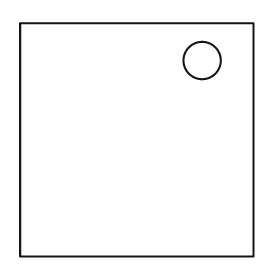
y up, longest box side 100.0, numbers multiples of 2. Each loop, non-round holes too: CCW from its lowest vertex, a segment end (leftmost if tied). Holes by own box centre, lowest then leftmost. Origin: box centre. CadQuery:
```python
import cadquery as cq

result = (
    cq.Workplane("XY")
    .moveTo(-50.0, -50.0)
    .lineTo(50.0, -50.0)
    .lineTo(50.0, 50.0)
    .lineTo(-50.0, 50.0)
    .close()
    .moveTo(28.0, 34.0)
    .circle(8.0)
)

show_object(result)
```